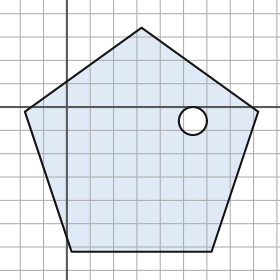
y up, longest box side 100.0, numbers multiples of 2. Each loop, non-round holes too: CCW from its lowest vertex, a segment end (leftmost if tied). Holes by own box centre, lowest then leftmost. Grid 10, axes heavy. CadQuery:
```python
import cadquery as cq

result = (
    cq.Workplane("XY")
    .moveTo(2.0, -62.0)
    .lineTo(62.0, -62.0)
    .lineTo(82.0, -2.0)
    .lineTo(32.0, 34.0)
    .lineTo(-18.0, -2.0)
    .close()
    .moveTo(54.0, -6.0)
    .circle(6.0)
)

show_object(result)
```